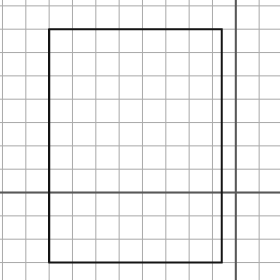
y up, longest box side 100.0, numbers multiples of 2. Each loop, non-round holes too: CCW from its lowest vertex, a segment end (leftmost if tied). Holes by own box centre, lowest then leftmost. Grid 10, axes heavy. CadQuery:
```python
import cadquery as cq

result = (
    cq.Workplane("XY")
    .moveTo(-80.0, -30.0)
    .lineTo(-6.0, -30.0)
    .lineTo(-6.0, 70.0)
    .lineTo(-80.0, 70.0)
    .close()
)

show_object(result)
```